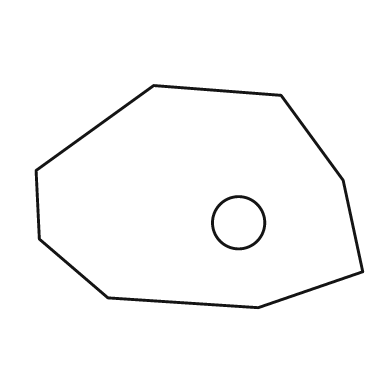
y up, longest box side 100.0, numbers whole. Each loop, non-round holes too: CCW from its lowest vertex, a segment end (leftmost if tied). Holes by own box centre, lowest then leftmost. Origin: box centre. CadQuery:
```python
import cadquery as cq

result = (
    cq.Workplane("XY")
    .moveTo(18.0, -34.0)
    .lineTo(50.0, -23.0)
    .lineTo(44.0, 5.0)
    .lineTo(25.0, 31.0)
    .lineTo(-14.0, 34.0)
    .lineTo(-50.0, 8.0)
    .lineTo(-49.0, -13.0)
    .lineTo(-28.0, -31.0)
    .close()
    .moveTo(12.0, -8.0)
    .circle(8.0)
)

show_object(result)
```